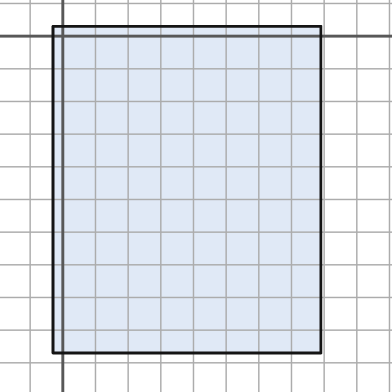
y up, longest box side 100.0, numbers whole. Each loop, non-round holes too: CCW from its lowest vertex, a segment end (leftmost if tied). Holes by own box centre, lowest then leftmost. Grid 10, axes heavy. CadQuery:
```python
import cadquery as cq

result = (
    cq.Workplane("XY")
    .moveTo(-3.0, -97.0)
    .lineTo(79.0, -97.0)
    .lineTo(79.0, 3.0)
    .lineTo(-3.0, 3.0)
    .close()
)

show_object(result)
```